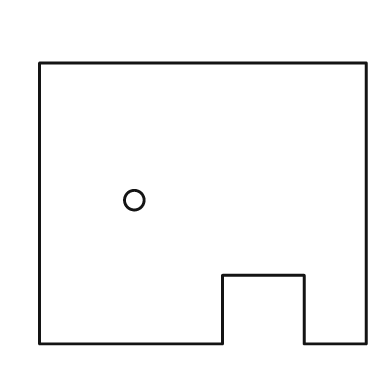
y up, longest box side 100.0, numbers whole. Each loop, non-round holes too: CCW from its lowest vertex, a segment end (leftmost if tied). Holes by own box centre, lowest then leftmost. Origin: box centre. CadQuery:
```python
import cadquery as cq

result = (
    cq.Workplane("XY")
    .moveTo(-50.0, -43.0)
    .lineTo(6.0, -43.0)
    .lineTo(6.0, -22.0)
    .lineTo(31.0, -22.0)
    .lineTo(31.0, -43.0)
    .lineTo(50.0, -43.0)
    .lineTo(50.0, 43.0)
    .lineTo(-50.0, 43.0)
    .close()
    .moveTo(-21.0, 1.0)
    .circle(3.0)
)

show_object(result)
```